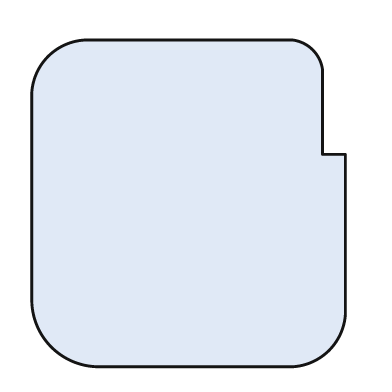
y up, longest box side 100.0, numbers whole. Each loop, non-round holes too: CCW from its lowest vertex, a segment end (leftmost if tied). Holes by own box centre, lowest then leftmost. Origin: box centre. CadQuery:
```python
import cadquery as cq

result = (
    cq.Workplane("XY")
    .moveTo(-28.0, -50.0)
    .lineTo(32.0, -50.0)
    .threePointArc((43.0, -45.0), (48.0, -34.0))
    .lineTo(48.0, 15.0)
    .lineTo(41.0, 15.0)
    .lineTo(41.0, 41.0)
    .threePointArc((38.0, 47.0), (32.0, 50.0))
    .lineTo(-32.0, 50.0)
    .threePointArc((-43.0, 45.0), (-48.0, 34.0))
    .lineTo(-48.0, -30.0)
    .threePointArc((-42.0, -44.0), (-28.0, -50.0))
    .close()
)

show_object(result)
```